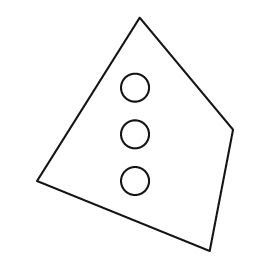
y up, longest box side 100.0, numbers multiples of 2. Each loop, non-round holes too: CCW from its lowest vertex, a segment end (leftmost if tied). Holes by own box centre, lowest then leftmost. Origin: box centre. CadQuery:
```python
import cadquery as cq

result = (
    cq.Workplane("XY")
    .moveTo(32.0, -50.0)
    .lineTo(42.0, 2.0)
    .lineTo(2.0, 50.0)
    .lineTo(-42.0, -20.0)
    .close()
    .moveTo(0.0, -20.0)
    .circle(6.0)
    .moveTo(0.0, 0.0)
    .circle(6.0)
    .moveTo(0.0, 20.0)
    .circle(6.0)
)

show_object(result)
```